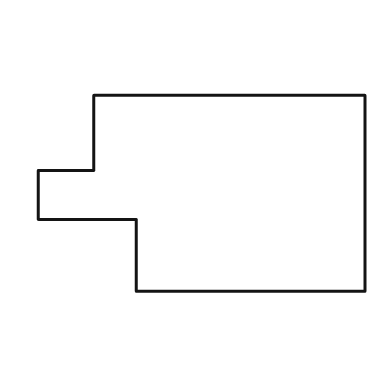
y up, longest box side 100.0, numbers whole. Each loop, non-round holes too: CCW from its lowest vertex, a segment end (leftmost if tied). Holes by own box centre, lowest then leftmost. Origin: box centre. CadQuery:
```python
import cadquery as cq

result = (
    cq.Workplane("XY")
    .moveTo(-20.0, -30.0)
    .lineTo(50.0, -30.0)
    .lineTo(50.0, 30.0)
    .lineTo(-33.0, 30.0)
    .lineTo(-33.0, 7.0)
    .lineTo(-50.0, 7.0)
    .lineTo(-50.0, -8.0)
    .lineTo(-20.0, -8.0)
    .close()
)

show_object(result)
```